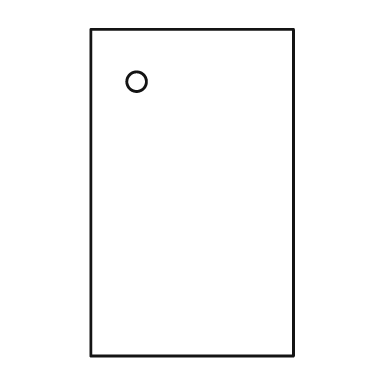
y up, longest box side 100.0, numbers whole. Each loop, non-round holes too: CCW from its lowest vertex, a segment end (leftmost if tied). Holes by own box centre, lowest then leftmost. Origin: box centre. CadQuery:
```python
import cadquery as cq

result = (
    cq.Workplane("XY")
    .moveTo(-31.0, -50.0)
    .lineTo(31.0, -50.0)
    .lineTo(31.0, 50.0)
    .lineTo(-31.0, 50.0)
    .close()
    .moveTo(-17.0, 34.0)
    .circle(3.0)
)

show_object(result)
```